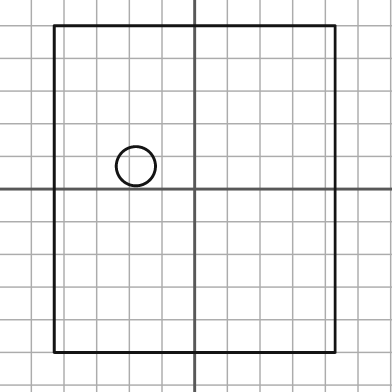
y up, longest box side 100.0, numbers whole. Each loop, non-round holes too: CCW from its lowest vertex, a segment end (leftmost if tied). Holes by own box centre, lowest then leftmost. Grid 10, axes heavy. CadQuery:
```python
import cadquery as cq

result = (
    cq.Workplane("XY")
    .moveTo(-43.0, -50.0)
    .lineTo(43.0, -50.0)
    .lineTo(43.0, 50.0)
    .lineTo(-43.0, 50.0)
    .close()
    .moveTo(-18.0, 7.0)
    .circle(6.0)
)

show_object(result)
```